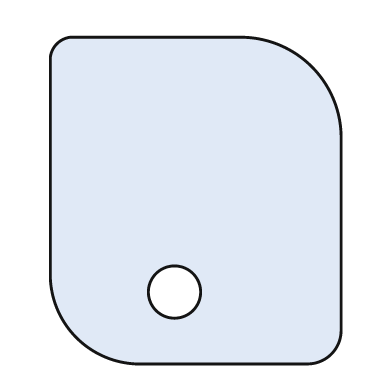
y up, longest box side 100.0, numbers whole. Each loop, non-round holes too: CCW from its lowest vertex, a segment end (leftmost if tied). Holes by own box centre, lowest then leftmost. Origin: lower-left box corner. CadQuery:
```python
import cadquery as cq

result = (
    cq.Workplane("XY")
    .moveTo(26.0, 0.0)
    .lineTo(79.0, 0.0)
    .threePointArc((86.0, 3.0), (89.0, 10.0))
    .lineTo(89.0, 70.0)
    .threePointArc((80.0, 91.0), (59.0, 100.0))
    .lineTo(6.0, 100.0)
    .threePointArc((2.0, 98.0), (0.0, 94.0))
    .lineTo(0.0, 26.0)
    .threePointArc((8.0, 8.0), (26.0, 0.0))
    .close()
    .moveTo(38.0, 22.0)
    .circle(8.0)
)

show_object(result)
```